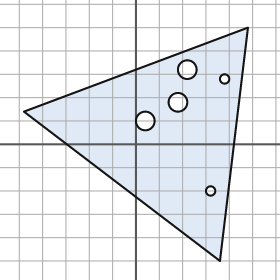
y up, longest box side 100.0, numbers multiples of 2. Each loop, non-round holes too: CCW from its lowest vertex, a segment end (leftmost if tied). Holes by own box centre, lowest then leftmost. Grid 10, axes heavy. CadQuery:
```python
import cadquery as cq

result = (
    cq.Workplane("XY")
    .moveTo(36.0, -50.0)
    .lineTo(48.0, 50.0)
    .lineTo(-48.0, 14.0)
    .close()
    .moveTo(32.0, -20.0)
    .circle(2.0)
    .moveTo(4.0, 10.0)
    .circle(4.0)
    .moveTo(18.0, 18.0)
    .circle(4.0)
    .moveTo(38.0, 28.0)
    .circle(2.0)
    .moveTo(22.0, 32.0)
    .circle(4.0)
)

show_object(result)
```